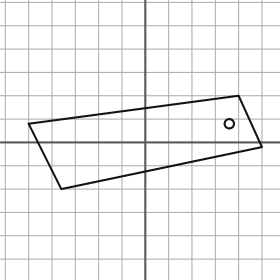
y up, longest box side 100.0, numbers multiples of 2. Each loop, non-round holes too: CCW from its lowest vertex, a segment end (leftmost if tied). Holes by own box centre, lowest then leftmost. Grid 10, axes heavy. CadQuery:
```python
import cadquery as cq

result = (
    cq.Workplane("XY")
    .moveTo(-36.0, -20.0)
    .lineTo(50.0, -2.0)
    .lineTo(40.0, 20.0)
    .lineTo(-50.0, 8.0)
    .close()
    .moveTo(36.0, 8.0)
    .circle(2.0)
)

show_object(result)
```